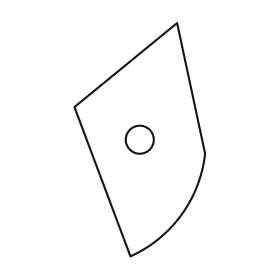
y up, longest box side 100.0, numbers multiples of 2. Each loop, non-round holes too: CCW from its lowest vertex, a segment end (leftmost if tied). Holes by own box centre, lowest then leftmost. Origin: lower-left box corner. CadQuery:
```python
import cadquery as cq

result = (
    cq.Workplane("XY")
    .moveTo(24.0, 0.0)
    .threePointArc((46.0, 18.0), (56.0, 44.0))
    .lineTo(44.0, 100.0)
    .lineTo(0.0, 64.0)
    .close()
    .moveTo(28.0, 50.0)
    .circle(6.0)
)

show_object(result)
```